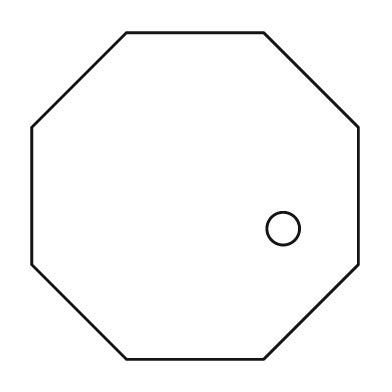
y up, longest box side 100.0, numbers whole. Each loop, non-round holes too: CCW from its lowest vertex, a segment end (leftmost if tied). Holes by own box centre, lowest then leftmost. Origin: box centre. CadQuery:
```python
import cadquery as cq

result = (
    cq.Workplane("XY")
    .moveTo(-21.0, -50.0)
    .lineTo(21.0, -50.0)
    .lineTo(50.0, -21.0)
    .lineTo(50.0, 21.0)
    .lineTo(21.0, 50.0)
    .lineTo(-21.0, 50.0)
    .lineTo(-50.0, 21.0)
    .lineTo(-50.0, -21.0)
    .close()
    .moveTo(27.0, -10.0)
    .circle(5.0)
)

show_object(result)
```